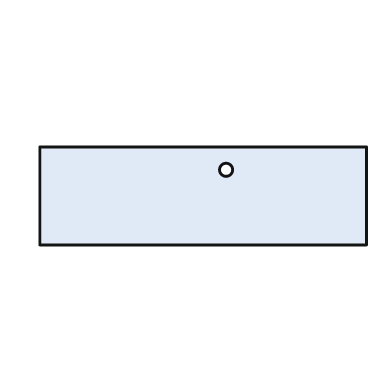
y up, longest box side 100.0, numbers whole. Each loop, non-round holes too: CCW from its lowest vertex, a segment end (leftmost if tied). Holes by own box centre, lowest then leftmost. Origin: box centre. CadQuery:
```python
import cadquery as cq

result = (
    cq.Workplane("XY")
    .moveTo(-50.0, -15.0)
    .lineTo(50.0, -15.0)
    .lineTo(50.0, 15.0)
    .lineTo(-50.0, 15.0)
    .close()
    .moveTo(7.0, 8.0)
    .circle(2.0)
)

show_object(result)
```